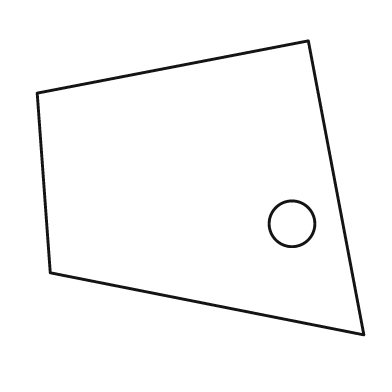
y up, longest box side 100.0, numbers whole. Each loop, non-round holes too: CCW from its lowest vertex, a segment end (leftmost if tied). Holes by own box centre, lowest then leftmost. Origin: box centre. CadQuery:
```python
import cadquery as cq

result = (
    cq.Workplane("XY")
    .moveTo(50.0, -45.0)
    .lineTo(33.0, 45.0)
    .lineTo(-50.0, 29.0)
    .lineTo(-46.0, -26.0)
    .close()
    .moveTo(28.0, -11.0)
    .circle(7.0)
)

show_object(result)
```